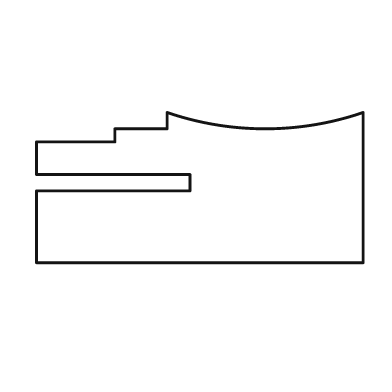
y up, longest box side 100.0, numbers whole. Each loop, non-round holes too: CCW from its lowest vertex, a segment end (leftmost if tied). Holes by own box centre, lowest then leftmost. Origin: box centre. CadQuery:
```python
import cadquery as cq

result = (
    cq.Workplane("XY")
    .moveTo(-50.0, -23.0)
    .lineTo(50.0, -23.0)
    .lineTo(50.0, 23.0)
    .threePointArc((20.0, 18.0), (-10.0, 23.0))
    .lineTo(-10.0, 18.0)
    .lineTo(-26.0, 18.0)
    .lineTo(-26.0, 14.0)
    .lineTo(-50.0, 14.0)
    .lineTo(-50.0, 4.0)
    .lineTo(-3.0, 4.0)
    .lineTo(-3.0, -1.0)
    .lineTo(-50.0, -1.0)
    .close()
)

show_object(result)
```